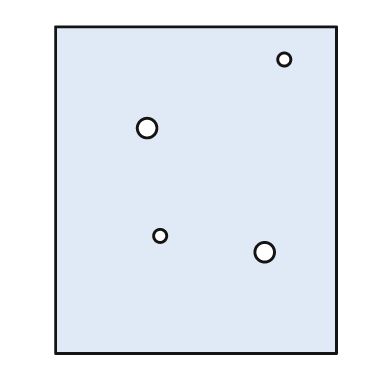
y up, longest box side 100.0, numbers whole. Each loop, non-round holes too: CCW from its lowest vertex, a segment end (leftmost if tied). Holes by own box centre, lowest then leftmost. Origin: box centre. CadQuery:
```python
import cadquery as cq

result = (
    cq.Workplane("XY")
    .moveTo(-43.0, -50.0)
    .lineTo(43.0, -50.0)
    .lineTo(43.0, 50.0)
    .lineTo(-43.0, 50.0)
    .close()
    .moveTo(21.0, -19.0)
    .circle(3.0)
    .moveTo(-11.0, -14.0)
    .circle(2.0)
    .moveTo(-15.0, 19.0)
    .circle(3.0)
    .moveTo(27.0, 40.0)
    .circle(2.0)
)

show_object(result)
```